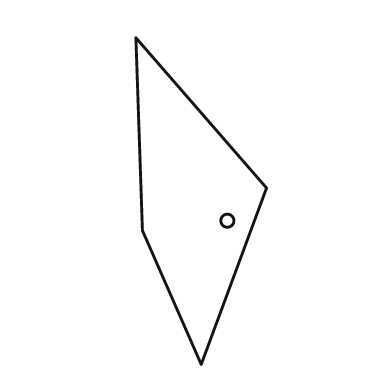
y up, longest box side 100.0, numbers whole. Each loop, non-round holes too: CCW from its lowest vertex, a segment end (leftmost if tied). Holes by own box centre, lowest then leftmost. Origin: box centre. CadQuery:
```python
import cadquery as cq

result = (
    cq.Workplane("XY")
    .moveTo(0.0, -50.0)
    .lineTo(20.0, 4.0)
    .lineTo(-20.0, 50.0)
    .lineTo(-18.0, -9.0)
    .close()
    .moveTo(8.0, -6.0)
    .circle(2.0)
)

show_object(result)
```